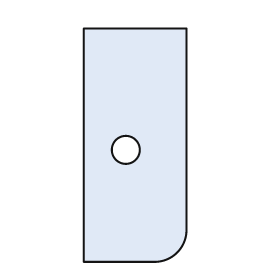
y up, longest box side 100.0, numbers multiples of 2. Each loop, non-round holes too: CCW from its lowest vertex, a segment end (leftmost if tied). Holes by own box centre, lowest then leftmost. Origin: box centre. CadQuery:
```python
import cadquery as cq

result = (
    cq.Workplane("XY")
    .moveTo(-22.0, -50.0)
    .lineTo(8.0, -50.0)
    .threePointArc((18.0, -46.0), (22.0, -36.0))
    .lineTo(22.0, 50.0)
    .lineTo(-22.0, 50.0)
    .close()
    .moveTo(-4.0, -2.0)
    .circle(6.0)
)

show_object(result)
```